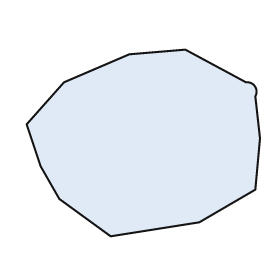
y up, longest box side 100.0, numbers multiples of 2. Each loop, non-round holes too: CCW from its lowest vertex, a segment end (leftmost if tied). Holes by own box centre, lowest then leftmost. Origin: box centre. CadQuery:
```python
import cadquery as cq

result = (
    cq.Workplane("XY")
    .moveTo(-14.0, -40.0)
    .lineTo(24.0, -34.0)
    .lineTo(48.0, -20.0)
    .lineTo(50.0, 2.0)
    .lineTo(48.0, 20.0)
    .threePointArc((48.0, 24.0), (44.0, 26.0))
    .lineTo(18.0, 40.0)
    .lineTo(-6.0, 38.0)
    .lineTo(-34.0, 26.0)
    .lineTo(-50.0, 8.0)
    .lineTo(-44.0, -10.0)
    .lineTo(-36.0, -24.0)
    .close()
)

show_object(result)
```